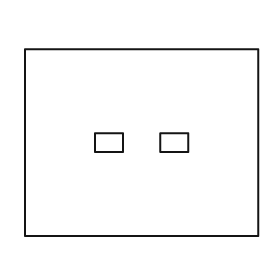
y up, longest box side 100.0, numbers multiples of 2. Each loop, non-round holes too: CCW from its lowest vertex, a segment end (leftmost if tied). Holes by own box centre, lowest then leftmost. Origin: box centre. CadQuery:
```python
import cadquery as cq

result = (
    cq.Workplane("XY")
    .moveTo(-50.0, -40.0)
    .lineTo(50.0, -40.0)
    .lineTo(50.0, 40.0)
    .lineTo(-50.0, 40.0)
    .close()
    .moveTo(-20.0, -4.0)
    .lineTo(-8.0, -4.0)
    .lineTo(-8.0, 4.0)
    .lineTo(-20.0, 4.0)
    .close()
    .moveTo(8.0, -4.0)
    .lineTo(20.0, -4.0)
    .lineTo(20.0, 4.0)
    .lineTo(8.0, 4.0)
    .close()
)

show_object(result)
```